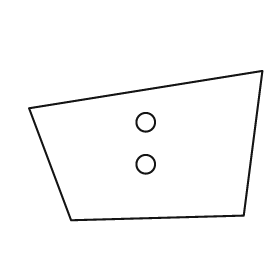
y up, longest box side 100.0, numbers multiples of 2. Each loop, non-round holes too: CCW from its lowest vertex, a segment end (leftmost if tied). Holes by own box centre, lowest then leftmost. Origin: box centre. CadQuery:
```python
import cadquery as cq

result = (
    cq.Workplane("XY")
    .moveTo(-32.0, -32.0)
    .lineTo(42.0, -30.0)
    .lineTo(50.0, 32.0)
    .lineTo(-50.0, 16.0)
    .close()
    .moveTo(0.0, -8.0)
    .circle(4.0)
    .moveTo(0.0, 10.0)
    .circle(4.0)
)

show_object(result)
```